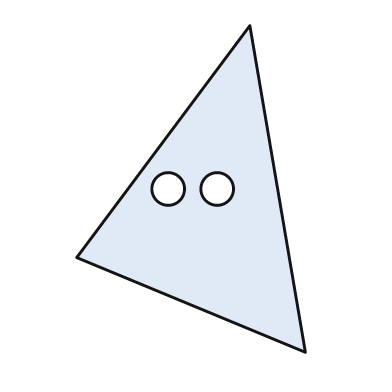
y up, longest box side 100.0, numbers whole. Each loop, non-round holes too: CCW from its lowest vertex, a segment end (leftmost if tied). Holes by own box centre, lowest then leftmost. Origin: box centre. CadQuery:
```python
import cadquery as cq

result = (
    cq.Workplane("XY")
    .moveTo(35.0, -50.0)
    .lineTo(18.0, 50.0)
    .lineTo(-35.0, -21.0)
    .close()
    .moveTo(-7.0, 0.0)
    .circle(5.0)
    .moveTo(8.0, 0.0)
    .circle(5.0)
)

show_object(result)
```